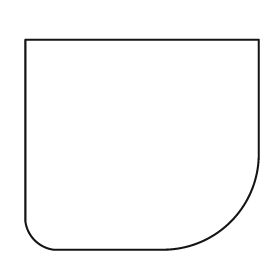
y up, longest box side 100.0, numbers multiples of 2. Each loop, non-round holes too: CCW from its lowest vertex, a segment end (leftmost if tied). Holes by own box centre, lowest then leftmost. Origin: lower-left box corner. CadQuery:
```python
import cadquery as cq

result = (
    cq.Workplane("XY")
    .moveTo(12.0, 0.0)
    .lineTo(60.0, 0.0)
    .threePointArc((88.0, 12.0), (100.0, 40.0))
    .lineTo(100.0, 90.0)
    .lineTo(0.0, 90.0)
    .lineTo(0.0, 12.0)
    .threePointArc((4.0, 4.0), (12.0, 0.0))
    .close()
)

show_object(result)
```